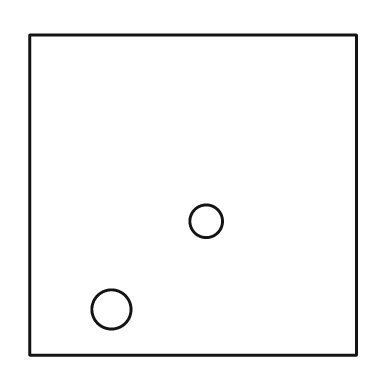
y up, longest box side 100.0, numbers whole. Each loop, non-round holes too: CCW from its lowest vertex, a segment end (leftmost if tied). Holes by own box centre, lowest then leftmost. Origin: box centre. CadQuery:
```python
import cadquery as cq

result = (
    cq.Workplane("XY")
    .moveTo(-50.0, -49.0)
    .lineTo(50.0, -49.0)
    .lineTo(50.0, 49.0)
    .lineTo(-50.0, 49.0)
    .close()
    .moveTo(-25.0, -35.0)
    .circle(6.0)
    .moveTo(4.0, -8.0)
    .circle(5.0)
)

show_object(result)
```